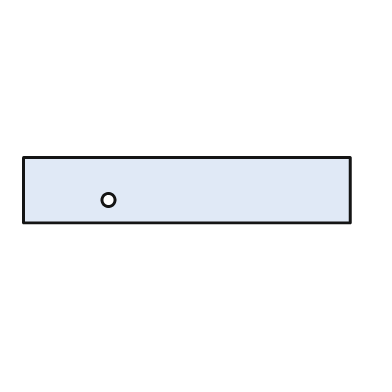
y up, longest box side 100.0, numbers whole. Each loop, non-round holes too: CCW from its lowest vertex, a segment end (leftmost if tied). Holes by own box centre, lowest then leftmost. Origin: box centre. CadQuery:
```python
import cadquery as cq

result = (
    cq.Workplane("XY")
    .moveTo(-50.0, -10.0)
    .lineTo(50.0, -10.0)
    .lineTo(50.0, 10.0)
    .lineTo(-50.0, 10.0)
    .close()
    .moveTo(-24.0, -3.0)
    .circle(2.0)
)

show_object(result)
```